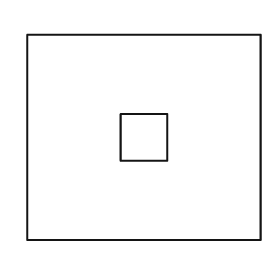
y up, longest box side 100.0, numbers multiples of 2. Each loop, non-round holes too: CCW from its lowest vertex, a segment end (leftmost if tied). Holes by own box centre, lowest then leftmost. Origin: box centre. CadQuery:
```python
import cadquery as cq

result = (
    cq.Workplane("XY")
    .moveTo(-50.0, -44.0)
    .lineTo(50.0, -44.0)
    .lineTo(50.0, 44.0)
    .lineTo(-50.0, 44.0)
    .close()
    .moveTo(-10.0, -10.0)
    .lineTo(10.0, -10.0)
    .lineTo(10.0, 10.0)
    .lineTo(-10.0, 10.0)
    .close()
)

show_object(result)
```